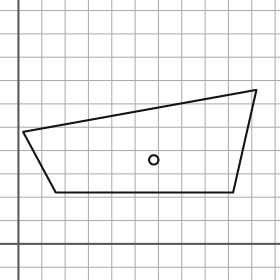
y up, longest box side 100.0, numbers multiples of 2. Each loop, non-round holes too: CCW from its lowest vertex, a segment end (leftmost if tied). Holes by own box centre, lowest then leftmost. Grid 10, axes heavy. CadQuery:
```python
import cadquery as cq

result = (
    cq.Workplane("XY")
    .moveTo(16.0, 22.0)
    .lineTo(92.0, 22.0)
    .lineTo(102.0, 66.0)
    .lineTo(2.0, 48.0)
    .close()
    .moveTo(58.0, 36.0)
    .circle(2.0)
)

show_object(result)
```